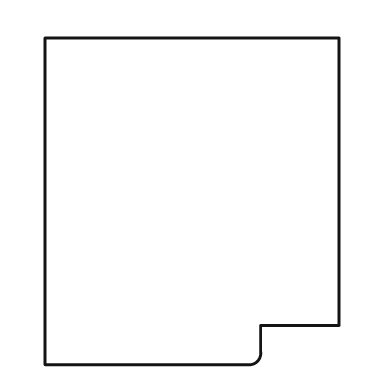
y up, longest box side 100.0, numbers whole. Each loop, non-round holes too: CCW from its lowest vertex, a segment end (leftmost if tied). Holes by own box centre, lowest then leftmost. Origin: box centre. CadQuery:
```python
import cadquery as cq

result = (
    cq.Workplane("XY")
    .moveTo(-45.0, -50.0)
    .lineTo(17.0, -50.0)
    .threePointArc((20.0, -49.0), (21.0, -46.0))
    .lineTo(21.0, -38.0)
    .lineTo(45.0, -38.0)
    .lineTo(45.0, 50.0)
    .lineTo(-45.0, 50.0)
    .close()
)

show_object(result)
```